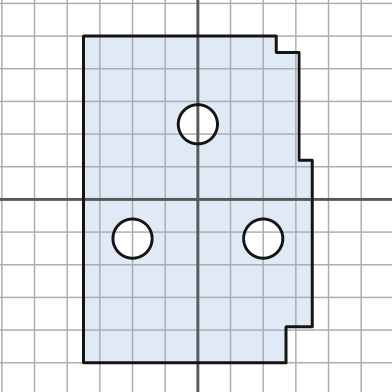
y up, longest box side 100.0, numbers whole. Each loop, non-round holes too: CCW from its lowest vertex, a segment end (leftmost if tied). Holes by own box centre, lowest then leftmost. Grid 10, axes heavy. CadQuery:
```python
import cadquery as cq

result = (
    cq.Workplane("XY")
    .moveTo(-35.0, -50.0)
    .lineTo(27.0, -50.0)
    .lineTo(27.0, -39.0)
    .lineTo(35.0, -39.0)
    .lineTo(35.0, 12.0)
    .lineTo(31.0, 12.0)
    .lineTo(31.0, 45.0)
    .lineTo(24.0, 45.0)
    .lineTo(24.0, 50.0)
    .lineTo(-35.0, 50.0)
    .close()
    .moveTo(-20.0, -12.0)
    .circle(6.0)
    .moveTo(20.0, -12.0)
    .circle(6.0)
    .moveTo(0.0, 23.0)
    .circle(6.0)
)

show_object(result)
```